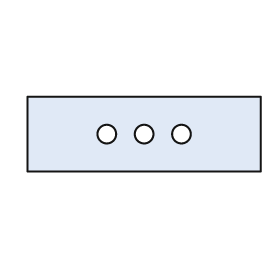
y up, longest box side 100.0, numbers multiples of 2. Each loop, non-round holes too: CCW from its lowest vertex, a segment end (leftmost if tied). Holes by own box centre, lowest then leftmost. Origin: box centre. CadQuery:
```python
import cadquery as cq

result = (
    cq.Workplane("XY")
    .moveTo(-50.0, -16.0)
    .lineTo(50.0, -16.0)
    .lineTo(50.0, 16.0)
    .lineTo(-50.0, 16.0)
    .close()
    .moveTo(-16.0, 0.0)
    .circle(4.0)
    .moveTo(0.0, 0.0)
    .circle(4.0)
    .moveTo(16.0, 0.0)
    .circle(4.0)
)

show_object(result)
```